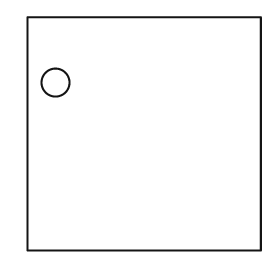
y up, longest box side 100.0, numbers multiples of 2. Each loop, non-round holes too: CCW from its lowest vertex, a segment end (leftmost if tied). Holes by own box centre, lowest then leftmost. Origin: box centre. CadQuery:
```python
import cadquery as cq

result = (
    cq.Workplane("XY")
    .moveTo(-50.0, -50.0)
    .lineTo(50.0, -50.0)
    .lineTo(50.0, 50.0)
    .lineTo(-50.0, 50.0)
    .close()
    .moveTo(-38.0, 22.0)
    .circle(6.0)
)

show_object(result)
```